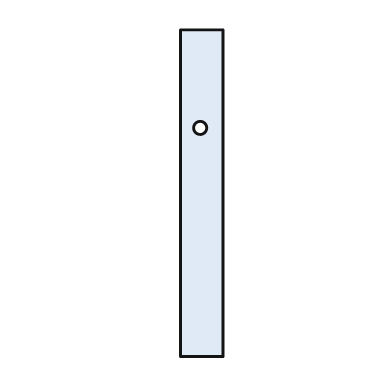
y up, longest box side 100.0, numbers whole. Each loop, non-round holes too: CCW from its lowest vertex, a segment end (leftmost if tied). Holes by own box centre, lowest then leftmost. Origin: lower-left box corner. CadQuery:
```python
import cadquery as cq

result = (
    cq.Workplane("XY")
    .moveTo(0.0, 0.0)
    .lineTo(13.0, 0.0)
    .lineTo(13.0, 100.0)
    .lineTo(0.0, 100.0)
    .close()
    .moveTo(6.0, 70.0)
    .circle(2.0)
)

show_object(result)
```